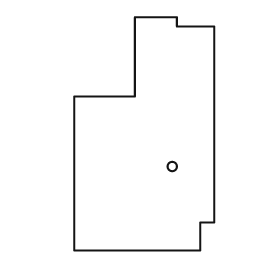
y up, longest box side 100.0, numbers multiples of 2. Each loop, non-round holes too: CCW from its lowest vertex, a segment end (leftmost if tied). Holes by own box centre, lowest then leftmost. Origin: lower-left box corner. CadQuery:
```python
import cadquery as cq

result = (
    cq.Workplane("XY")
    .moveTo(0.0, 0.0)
    .lineTo(54.0, 0.0)
    .lineTo(54.0, 12.0)
    .lineTo(60.0, 12.0)
    .lineTo(60.0, 96.0)
    .lineTo(44.0, 96.0)
    .lineTo(44.0, 100.0)
    .lineTo(26.0, 100.0)
    .lineTo(26.0, 66.0)
    .lineTo(0.0, 66.0)
    .close()
    .moveTo(42.0, 36.0)
    .circle(2.0)
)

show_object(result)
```